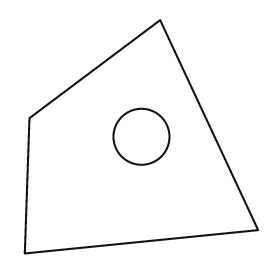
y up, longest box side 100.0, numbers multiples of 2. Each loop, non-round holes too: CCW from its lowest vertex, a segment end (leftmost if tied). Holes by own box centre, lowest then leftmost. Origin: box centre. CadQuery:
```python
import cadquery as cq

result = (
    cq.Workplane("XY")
    .moveTo(-50.0, -50.0)
    .lineTo(50.0, -40.0)
    .lineTo(8.0, 50.0)
    .lineTo(-48.0, 8.0)
    .close()
    .moveTo(0.0, 0.0)
    .circle(12.0)
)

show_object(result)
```